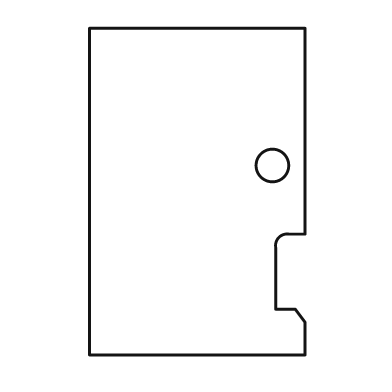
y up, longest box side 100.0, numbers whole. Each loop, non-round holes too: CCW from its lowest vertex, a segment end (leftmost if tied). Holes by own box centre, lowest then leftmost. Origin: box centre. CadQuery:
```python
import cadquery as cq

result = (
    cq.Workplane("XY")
    .moveTo(-33.0, -50.0)
    .lineTo(33.0, -50.0)
    .lineTo(33.0, -40.0)
    .lineTo(30.0, -36.0)
    .lineTo(24.0, -36.0)
    .lineTo(24.0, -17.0)
    .threePointArc((25.0, -14.0), (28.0, -13.0))
    .lineTo(33.0, -13.0)
    .lineTo(33.0, 50.0)
    .lineTo(-33.0, 50.0)
    .close()
    .moveTo(23.0, 8.0)
    .circle(5.0)
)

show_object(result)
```